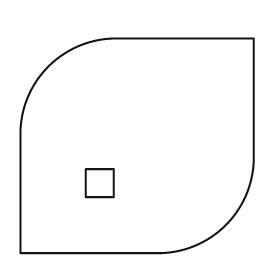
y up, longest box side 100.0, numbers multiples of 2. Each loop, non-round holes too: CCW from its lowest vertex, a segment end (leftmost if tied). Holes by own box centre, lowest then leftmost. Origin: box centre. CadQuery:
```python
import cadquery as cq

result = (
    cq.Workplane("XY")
    .moveTo(-50.0, -46.0)
    .lineTo(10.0, -46.0)
    .threePointArc((38.0, -34.0), (50.0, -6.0))
    .lineTo(50.0, 46.0)
    .lineTo(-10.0, 46.0)
    .threePointArc((-38.0, 34.0), (-50.0, 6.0))
    .close()
    .moveTo(-22.0, -22.0)
    .lineTo(-10.0, -22.0)
    .lineTo(-10.0, -10.0)
    .lineTo(-22.0, -10.0)
    .close()
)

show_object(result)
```